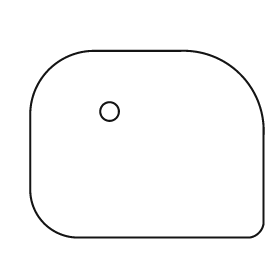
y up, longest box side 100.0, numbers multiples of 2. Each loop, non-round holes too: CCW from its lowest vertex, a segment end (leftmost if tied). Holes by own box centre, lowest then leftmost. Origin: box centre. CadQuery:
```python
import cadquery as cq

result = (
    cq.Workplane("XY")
    .moveTo(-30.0, -40.0)
    .lineTo(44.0, -40.0)
    .threePointArc((48.0, -38.0), (50.0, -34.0))
    .lineTo(50.0, 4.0)
    .threePointArc((40.0, 30.0), (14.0, 40.0))
    .lineTo(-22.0, 40.0)
    .threePointArc((-42.0, 32.0), (-50.0, 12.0))
    .lineTo(-50.0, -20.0)
    .threePointArc((-44.0, -34.0), (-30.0, -40.0))
    .close()
    .moveTo(-16.0, 14.0)
    .circle(4.0)
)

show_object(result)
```